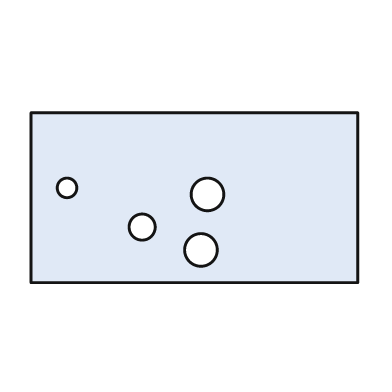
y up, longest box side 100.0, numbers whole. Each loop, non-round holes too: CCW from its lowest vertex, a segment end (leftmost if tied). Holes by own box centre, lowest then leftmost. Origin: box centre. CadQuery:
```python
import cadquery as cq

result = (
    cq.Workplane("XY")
    .moveTo(-50.0, -26.0)
    .lineTo(50.0, -26.0)
    .lineTo(50.0, 26.0)
    .lineTo(-50.0, 26.0)
    .close()
    .moveTo(2.0, -16.0)
    .circle(5.0)
    .moveTo(-16.0, -9.0)
    .circle(4.0)
    .moveTo(4.0, 1.0)
    .circle(5.0)
    .moveTo(-39.0, 3.0)
    .circle(3.0)
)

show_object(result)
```